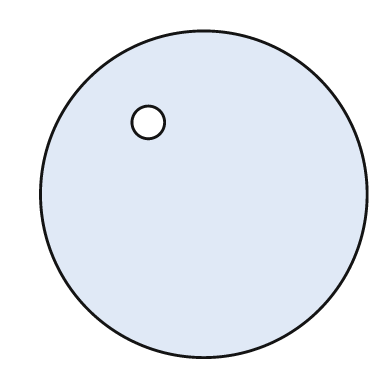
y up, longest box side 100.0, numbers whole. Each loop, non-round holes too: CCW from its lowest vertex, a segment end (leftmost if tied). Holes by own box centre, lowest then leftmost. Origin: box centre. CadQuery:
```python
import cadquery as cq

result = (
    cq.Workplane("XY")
    .moveTo(0.0, 0.0)
    .circle(50.0)
    .moveTo(-17.0, 22.0)
    .circle(5.0)
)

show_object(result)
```